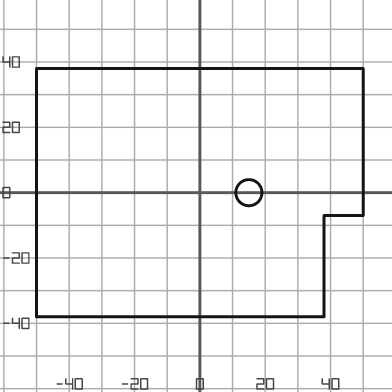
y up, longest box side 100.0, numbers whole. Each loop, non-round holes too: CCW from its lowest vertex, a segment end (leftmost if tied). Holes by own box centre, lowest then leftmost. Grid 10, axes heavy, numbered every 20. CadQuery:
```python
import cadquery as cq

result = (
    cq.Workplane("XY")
    .moveTo(-50.0, -38.0)
    .lineTo(38.0, -38.0)
    .lineTo(38.0, -7.0)
    .lineTo(50.0, -7.0)
    .lineTo(50.0, 38.0)
    .lineTo(-50.0, 38.0)
    .close()
    .moveTo(15.0, 0.0)
    .circle(4.0)
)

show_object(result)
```